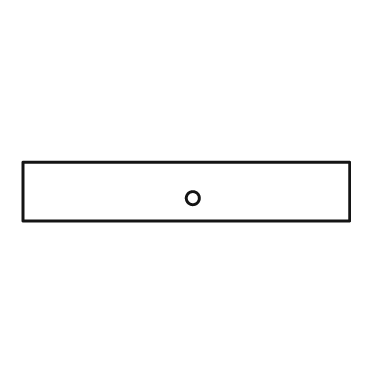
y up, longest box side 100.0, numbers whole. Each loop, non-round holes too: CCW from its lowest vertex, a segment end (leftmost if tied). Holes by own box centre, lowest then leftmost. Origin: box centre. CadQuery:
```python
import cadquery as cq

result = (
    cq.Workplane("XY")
    .moveTo(-50.0, -9.0)
    .lineTo(50.0, -9.0)
    .lineTo(50.0, 9.0)
    .lineTo(-50.0, 9.0)
    .close()
    .moveTo(2.0, -2.0)
    .circle(2.0)
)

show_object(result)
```